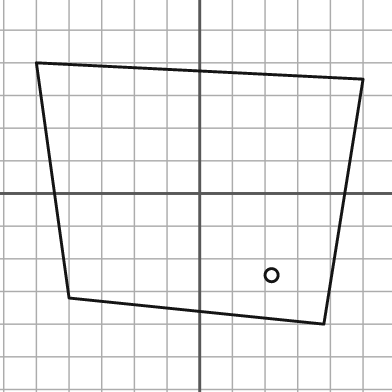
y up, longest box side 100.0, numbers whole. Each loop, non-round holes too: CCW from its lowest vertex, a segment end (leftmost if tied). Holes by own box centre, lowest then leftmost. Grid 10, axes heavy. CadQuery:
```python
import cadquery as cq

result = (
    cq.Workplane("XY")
    .moveTo(38.0, -40.0)
    .lineTo(50.0, 35.0)
    .lineTo(-50.0, 40.0)
    .lineTo(-40.0, -32.0)
    .close()
    .moveTo(22.0, -25.0)
    .circle(2.0)
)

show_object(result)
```